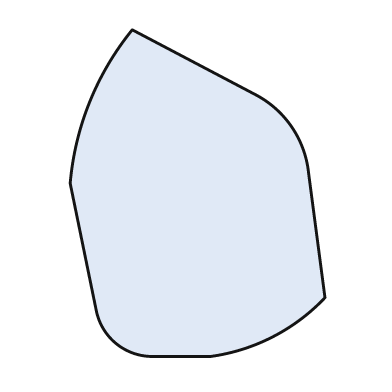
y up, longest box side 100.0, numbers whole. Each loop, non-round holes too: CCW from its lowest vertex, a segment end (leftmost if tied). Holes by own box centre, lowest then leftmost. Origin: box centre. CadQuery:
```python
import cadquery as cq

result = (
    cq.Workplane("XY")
    .moveTo(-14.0, -50.0)
    .lineTo(4.0, -50.0)
    .threePointArc((23.0, -44.0), (39.0, -32.0))
    .lineTo(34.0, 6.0)
    .threePointArc((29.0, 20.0), (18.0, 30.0))
    .lineTo(-20.0, 50.0)
    .threePointArc((-33.0, 28.0), (-39.0, 3.0))
    .lineTo(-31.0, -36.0)
    .threePointArc((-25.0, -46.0), (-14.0, -50.0))
    .close()
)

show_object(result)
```